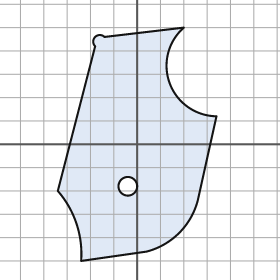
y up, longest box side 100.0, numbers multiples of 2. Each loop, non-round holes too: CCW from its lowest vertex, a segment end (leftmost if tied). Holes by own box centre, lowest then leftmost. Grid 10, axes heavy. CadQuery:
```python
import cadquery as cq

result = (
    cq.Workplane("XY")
    .moveTo(-24.0, -50.0)
    .lineTo(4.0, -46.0)
    .threePointArc((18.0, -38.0), (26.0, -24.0))
    .lineTo(34.0, 12.0)
    .threePointArc((14.0, 26.0), (20.0, 50.0))
    .lineTo(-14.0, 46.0)
    .threePointArc((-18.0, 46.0), (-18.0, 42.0))
    .lineTo(-34.0, -20.0)
    .threePointArc((-26.0, -34.0), (-24.0, -50.0))
    .close()
    .moveTo(-4.0, -18.0)
    .circle(4.0)
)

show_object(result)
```